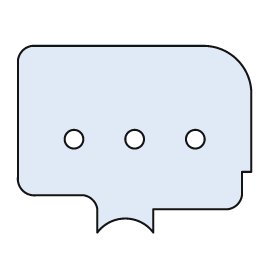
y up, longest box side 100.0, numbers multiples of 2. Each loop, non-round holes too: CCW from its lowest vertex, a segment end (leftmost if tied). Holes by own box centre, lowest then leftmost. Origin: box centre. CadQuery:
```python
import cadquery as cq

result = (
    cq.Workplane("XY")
    .moveTo(-16.0, -40.0)
    .threePointArc((-4.0, -34.0), (8.0, -40.0))
    .lineTo(8.0, -30.0)
    .lineTo(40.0, -30.0)
    .threePointArc((44.0, -28.0), (46.0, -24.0))
    .lineTo(46.0, -14.0)
    .lineTo(50.0, -14.0)
    .lineTo(50.0, 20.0)
    .threePointArc((44.0, 34.0), (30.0, 40.0))
    .lineTo(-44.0, 40.0)
    .threePointArc((-48.0, 38.0), (-50.0, 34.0))
    .lineTo(-50.0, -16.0)
    .threePointArc((-48.0, -22.0), (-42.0, -24.0))
    .lineTo(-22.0, -24.0)
    .threePointArc((-18.0, -26.0), (-16.0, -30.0))
    .close()
    .moveTo(-26.0, 0.0)
    .circle(4.0)
    .moveTo(0.0, 0.0)
    .circle(4.0)
    .moveTo(26.0, 0.0)
    .circle(4.0)
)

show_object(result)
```